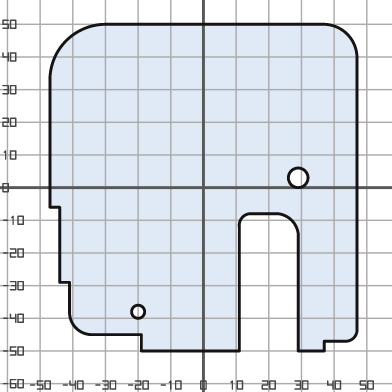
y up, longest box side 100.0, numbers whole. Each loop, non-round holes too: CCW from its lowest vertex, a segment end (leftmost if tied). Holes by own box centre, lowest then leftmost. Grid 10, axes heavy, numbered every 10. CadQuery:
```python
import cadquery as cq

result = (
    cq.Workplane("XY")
    .moveTo(-19.0, -50.0)
    .lineTo(11.0, -50.0)
    .lineTo(11.0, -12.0)
    .threePointArc((12.0, -9.0), (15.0, -8.0))
    .lineTo(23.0, -8.0)
    .threePointArc((27.0, -10.0), (29.0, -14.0))
    .lineTo(29.0, -50.0)
    .lineTo(37.0, -50.0)
    .lineTo(37.0, -47.0)
    .lineTo(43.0, -47.0)
    .threePointArc((46.0, -46.0), (47.0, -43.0))
    .lineTo(47.0, 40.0)
    .threePointArc((44.0, 47.0), (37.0, 50.0))
    .lineTo(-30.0, 50.0)
    .threePointArc((-42.0, 45.0), (-47.0, 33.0))
    .lineTo(-47.0, -6.0)
    .lineTo(-44.0, -6.0)
    .lineTo(-44.0, -29.0)
    .lineTo(-41.0, -29.0)
    .lineTo(-41.0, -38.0)
    .threePointArc((-39.0, -43.0), (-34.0, -45.0))
    .lineTo(-19.0, -45.0)
    .close()
    .moveTo(-20.0, -38.0)
    .circle(2.0)
    .moveTo(29.0, 3.0)
    .circle(3.0)
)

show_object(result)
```